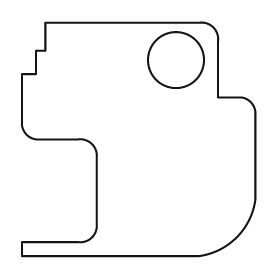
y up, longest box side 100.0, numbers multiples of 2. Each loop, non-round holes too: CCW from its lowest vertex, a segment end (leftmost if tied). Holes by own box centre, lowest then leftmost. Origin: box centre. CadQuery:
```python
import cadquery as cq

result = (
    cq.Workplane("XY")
    .moveTo(-50.0, -50.0)
    .lineTo(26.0, -50.0)
    .threePointArc((42.0, -42.0), (50.0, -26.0))
    .lineTo(50.0, 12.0)
    .threePointArc((48.0, 16.0), (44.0, 18.0))
    .lineTo(34.0, 18.0)
    .lineTo(34.0, 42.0)
    .threePointArc((32.0, 48.0), (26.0, 50.0))
    .lineTo(-40.0, 50.0)
    .lineTo(-40.0, 38.0)
    .lineTo(-44.0, 38.0)
    .lineTo(-44.0, 28.0)
    .lineTo(-50.0, 28.0)
    .lineTo(-50.0, 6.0)
    .threePointArc((-48.0, 2.0), (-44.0, 0.0))
    .lineTo(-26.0, 0.0)
    .threePointArc((-20.0, -2.0), (-18.0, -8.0))
    .lineTo(-18.0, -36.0)
    .threePointArc((-20.0, -42.0), (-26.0, -44.0))
    .lineTo(-50.0, -44.0)
    .close()
    .moveTo(16.0, 34.0)
    .circle(12.0)
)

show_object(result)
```